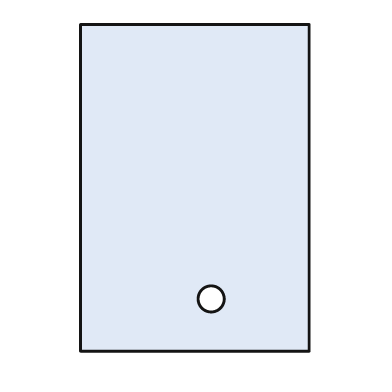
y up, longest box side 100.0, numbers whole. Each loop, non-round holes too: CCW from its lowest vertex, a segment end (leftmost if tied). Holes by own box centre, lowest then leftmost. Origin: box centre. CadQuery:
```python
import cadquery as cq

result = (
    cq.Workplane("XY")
    .moveTo(-35.0, -50.0)
    .lineTo(35.0, -50.0)
    .lineTo(35.0, 50.0)
    .lineTo(-35.0, 50.0)
    .close()
    .moveTo(5.0, -34.0)
    .circle(4.0)
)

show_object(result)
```